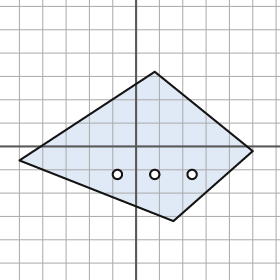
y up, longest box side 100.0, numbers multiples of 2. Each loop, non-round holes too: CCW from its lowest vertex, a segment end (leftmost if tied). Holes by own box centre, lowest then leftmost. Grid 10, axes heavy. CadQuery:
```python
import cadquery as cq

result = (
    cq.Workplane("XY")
    .moveTo(16.0, -32.0)
    .lineTo(50.0, -2.0)
    .lineTo(8.0, 32.0)
    .lineTo(-50.0, -6.0)
    .close()
    .moveTo(-8.0, -12.0)
    .circle(2.0)
    .moveTo(8.0, -12.0)
    .circle(2.0)
    .moveTo(24.0, -12.0)
    .circle(2.0)
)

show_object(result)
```